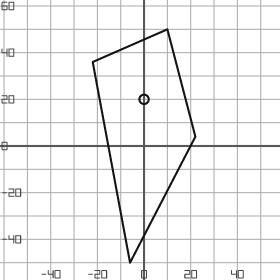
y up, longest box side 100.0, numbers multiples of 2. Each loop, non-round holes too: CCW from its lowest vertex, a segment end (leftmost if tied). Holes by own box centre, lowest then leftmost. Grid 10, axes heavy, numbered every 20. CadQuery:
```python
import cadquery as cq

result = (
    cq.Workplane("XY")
    .moveTo(-6.0, -50.0)
    .lineTo(22.0, 4.0)
    .lineTo(10.0, 50.0)
    .lineTo(-22.0, 36.0)
    .close()
    .moveTo(0.0, 20.0)
    .circle(2.0)
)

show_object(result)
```